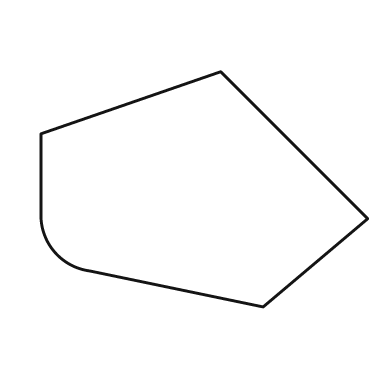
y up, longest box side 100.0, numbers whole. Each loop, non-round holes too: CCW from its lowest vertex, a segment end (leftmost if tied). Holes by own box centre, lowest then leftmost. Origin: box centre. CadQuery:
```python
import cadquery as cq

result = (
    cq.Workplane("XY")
    .moveTo(18.0, -36.0)
    .lineTo(50.0, -9.0)
    .lineTo(5.0, 36.0)
    .lineTo(-50.0, 17.0)
    .lineTo(-50.0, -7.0)
    .threePointArc((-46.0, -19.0), (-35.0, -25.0))
    .close()
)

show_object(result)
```